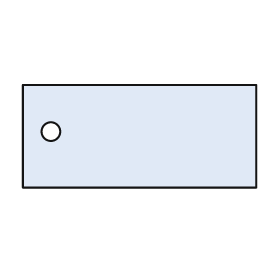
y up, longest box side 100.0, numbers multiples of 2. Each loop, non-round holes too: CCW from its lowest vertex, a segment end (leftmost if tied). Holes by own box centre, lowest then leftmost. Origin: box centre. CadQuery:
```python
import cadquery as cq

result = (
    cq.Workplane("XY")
    .moveTo(-50.0, -22.0)
    .lineTo(50.0, -22.0)
    .lineTo(50.0, 22.0)
    .lineTo(-50.0, 22.0)
    .close()
    .moveTo(-38.0, 2.0)
    .circle(4.0)
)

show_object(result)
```